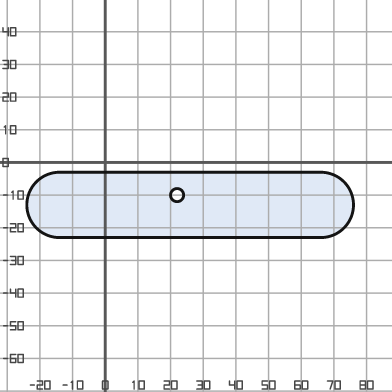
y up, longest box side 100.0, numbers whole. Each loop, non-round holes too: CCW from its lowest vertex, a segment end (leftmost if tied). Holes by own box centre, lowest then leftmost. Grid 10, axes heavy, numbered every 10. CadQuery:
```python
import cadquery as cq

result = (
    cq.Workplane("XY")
    .moveTo(-14.0, -23.0)
    .lineTo(66.0, -23.0)
    .threePointArc((76.0, -13.0), (66.0, -3.0))
    .lineTo(-14.0, -3.0)
    .threePointArc((-24.0, -13.0), (-14.0, -23.0))
    .close()
    .moveTo(22.0, -10.0)
    .circle(2.0)
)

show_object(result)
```